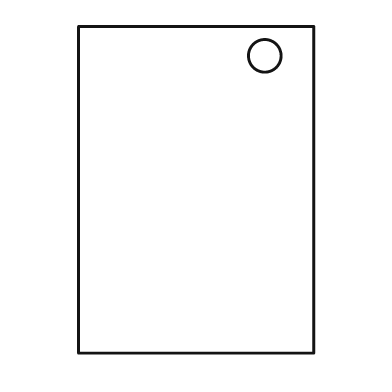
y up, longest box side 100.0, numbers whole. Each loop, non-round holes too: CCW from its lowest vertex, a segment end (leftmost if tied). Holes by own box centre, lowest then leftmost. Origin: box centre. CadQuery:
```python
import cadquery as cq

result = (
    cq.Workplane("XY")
    .moveTo(-36.0, -50.0)
    .lineTo(36.0, -50.0)
    .lineTo(36.0, 50.0)
    .lineTo(-36.0, 50.0)
    .close()
    .moveTo(21.0, 41.0)
    .circle(5.0)
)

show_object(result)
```